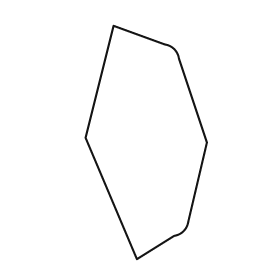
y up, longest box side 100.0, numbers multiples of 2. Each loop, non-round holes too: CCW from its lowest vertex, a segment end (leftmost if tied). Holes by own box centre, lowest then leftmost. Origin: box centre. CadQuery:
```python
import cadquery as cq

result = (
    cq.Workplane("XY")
    .moveTo(-4.0, -50.0)
    .lineTo(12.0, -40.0)
    .threePointArc((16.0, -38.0), (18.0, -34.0))
    .lineTo(26.0, 0.0)
    .lineTo(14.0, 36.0)
    .threePointArc((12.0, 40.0), (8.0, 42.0))
    .lineTo(-14.0, 50.0)
    .lineTo(-26.0, 2.0)
    .close()
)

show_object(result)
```